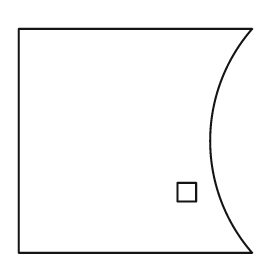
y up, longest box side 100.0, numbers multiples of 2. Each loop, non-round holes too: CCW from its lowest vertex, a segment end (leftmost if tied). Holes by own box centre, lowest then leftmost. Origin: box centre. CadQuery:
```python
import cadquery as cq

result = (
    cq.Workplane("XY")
    .moveTo(-50.0, -48.0)
    .lineTo(50.0, -48.0)
    .threePointArc((32.0, 0.0), (50.0, 48.0))
    .lineTo(-50.0, 48.0)
    .close()
    .moveTo(18.0, -26.0)
    .lineTo(26.0, -26.0)
    .lineTo(26.0, -18.0)
    .lineTo(18.0, -18.0)
    .close()
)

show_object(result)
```